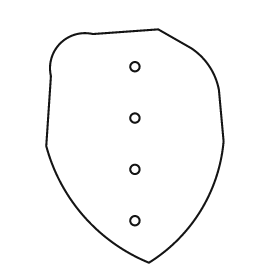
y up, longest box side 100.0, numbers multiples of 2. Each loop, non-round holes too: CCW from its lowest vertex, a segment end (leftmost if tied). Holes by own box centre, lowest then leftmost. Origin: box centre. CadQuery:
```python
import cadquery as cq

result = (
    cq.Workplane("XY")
    .moveTo(6.0, -50.0)
    .threePointArc((28.0, -28.0), (38.0, 2.0))
    .lineTo(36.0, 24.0)
    .threePointArc((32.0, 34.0), (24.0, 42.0))
    .lineTo(10.0, 50.0)
    .lineTo(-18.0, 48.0)
    .threePointArc((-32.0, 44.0), (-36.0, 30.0))
    .lineTo(-38.0, 0.0)
    .threePointArc((-22.0, -30.0), (6.0, -50.0))
    .close()
    .moveTo(0.0, -32.0)
    .circle(2.0)
    .moveTo(0.0, -10.0)
    .circle(2.0)
    .moveTo(0.0, 12.0)
    .circle(2.0)
    .moveTo(0.0, 34.0)
    .circle(2.0)
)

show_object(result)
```